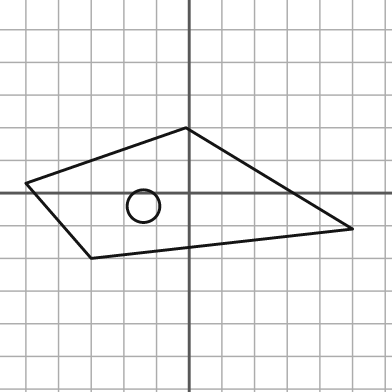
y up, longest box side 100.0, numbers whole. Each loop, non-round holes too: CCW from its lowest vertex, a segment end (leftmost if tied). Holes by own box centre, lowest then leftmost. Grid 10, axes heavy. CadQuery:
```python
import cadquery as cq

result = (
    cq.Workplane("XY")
    .moveTo(-30.0, -20.0)
    .lineTo(50.0, -11.0)
    .lineTo(-1.0, 20.0)
    .lineTo(-50.0, 3.0)
    .close()
    .moveTo(-14.0, -4.0)
    .circle(5.0)
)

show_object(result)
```